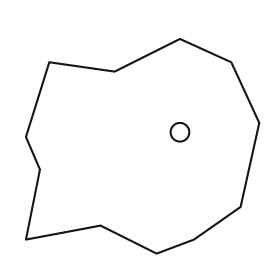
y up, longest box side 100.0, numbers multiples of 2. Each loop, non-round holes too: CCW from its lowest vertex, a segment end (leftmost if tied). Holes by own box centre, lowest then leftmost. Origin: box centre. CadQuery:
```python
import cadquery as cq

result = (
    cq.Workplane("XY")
    .moveTo(6.0, -46.0)
    .lineTo(22.0, -40.0)
    .lineTo(42.0, -26.0)
    .lineTo(50.0, 10.0)
    .lineTo(38.0, 36.0)
    .lineTo(16.0, 46.0)
    .lineTo(-12.0, 32.0)
    .lineTo(-40.0, 36.0)
    .lineTo(-50.0, 4.0)
    .lineTo(-44.0, -10.0)
    .lineTo(-50.0, -40.0)
    .lineTo(-18.0, -34.0)
    .close()
    .moveTo(16.0, 6.0)
    .circle(4.0)
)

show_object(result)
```